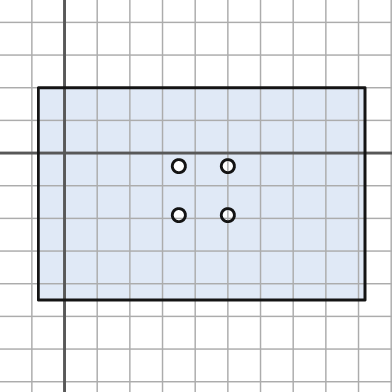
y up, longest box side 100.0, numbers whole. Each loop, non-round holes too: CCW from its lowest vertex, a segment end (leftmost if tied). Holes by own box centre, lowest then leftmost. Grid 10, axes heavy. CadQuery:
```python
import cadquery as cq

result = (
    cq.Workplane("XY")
    .moveTo(-8.0, -45.0)
    .lineTo(92.0, -45.0)
    .lineTo(92.0, 20.0)
    .lineTo(-8.0, 20.0)
    .close()
    .moveTo(35.0, -19.0)
    .circle(2.0)
    .moveTo(50.0, -19.0)
    .circle(2.0)
    .moveTo(35.0, -4.0)
    .circle(2.0)
    .moveTo(50.0, -4.0)
    .circle(2.0)
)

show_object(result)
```